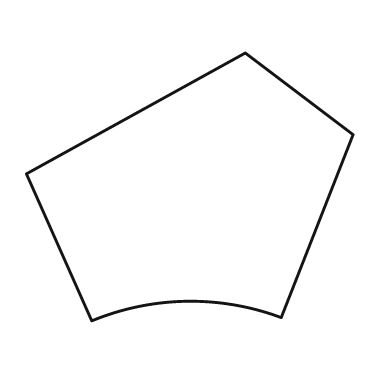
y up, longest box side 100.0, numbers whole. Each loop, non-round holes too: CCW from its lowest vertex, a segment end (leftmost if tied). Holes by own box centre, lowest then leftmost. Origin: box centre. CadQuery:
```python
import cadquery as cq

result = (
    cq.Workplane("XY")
    .moveTo(-30.0, -41.0)
    .threePointArc((-1.0, -35.0), (28.0, -40.0))
    .lineTo(50.0, 16.0)
    .lineTo(17.0, 41.0)
    .lineTo(-50.0, 4.0)
    .close()
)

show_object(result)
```